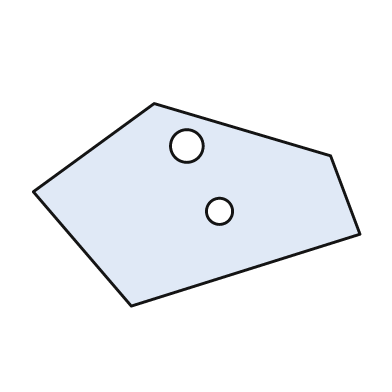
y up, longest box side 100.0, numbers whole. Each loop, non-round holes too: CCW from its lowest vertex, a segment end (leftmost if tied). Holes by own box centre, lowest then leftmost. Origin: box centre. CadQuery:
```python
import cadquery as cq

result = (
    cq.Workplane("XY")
    .moveTo(-20.0, -31.0)
    .lineTo(50.0, -9.0)
    .lineTo(41.0, 15.0)
    .lineTo(-13.0, 31.0)
    .lineTo(-50.0, 4.0)
    .close()
    .moveTo(7.0, -2.0)
    .circle(4.0)
    .moveTo(-3.0, 18.0)
    .circle(5.0)
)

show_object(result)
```